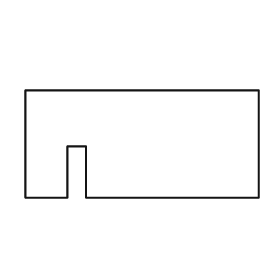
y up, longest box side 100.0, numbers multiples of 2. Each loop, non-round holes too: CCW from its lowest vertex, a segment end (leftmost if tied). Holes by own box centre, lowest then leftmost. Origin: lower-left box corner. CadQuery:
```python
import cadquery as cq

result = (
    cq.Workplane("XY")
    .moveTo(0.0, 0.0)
    .lineTo(18.0, 0.0)
    .lineTo(18.0, 22.0)
    .lineTo(26.0, 22.0)
    .lineTo(26.0, 0.0)
    .lineTo(100.0, 0.0)
    .lineTo(100.0, 46.0)
    .lineTo(0.0, 46.0)
    .close()
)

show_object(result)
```